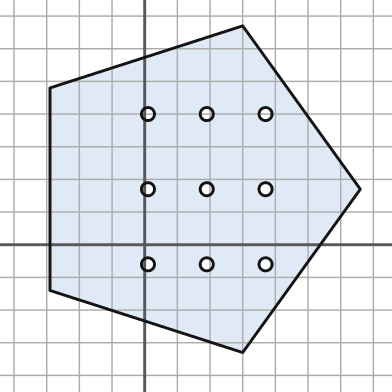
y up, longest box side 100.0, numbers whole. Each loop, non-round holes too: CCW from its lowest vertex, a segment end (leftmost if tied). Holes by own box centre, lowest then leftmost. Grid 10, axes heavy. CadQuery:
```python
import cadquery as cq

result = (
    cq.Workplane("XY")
    .moveTo(30.0, -33.0)
    .lineTo(66.0, 17.0)
    .lineTo(30.0, 67.0)
    .lineTo(-29.0, 48.0)
    .lineTo(-29.0, -14.0)
    .close()
    .moveTo(1.0, -6.0)
    .circle(2.0)
    .moveTo(19.0, -6.0)
    .circle(2.0)
    .moveTo(37.0, -6.0)
    .circle(2.0)
    .moveTo(1.0, 17.0)
    .circle(2.0)
    .moveTo(19.0, 17.0)
    .circle(2.0)
    .moveTo(37.0, 17.0)
    .circle(2.0)
    .moveTo(1.0, 40.0)
    .circle(2.0)
    .moveTo(19.0, 40.0)
    .circle(2.0)
    .moveTo(37.0, 40.0)
    .circle(2.0)
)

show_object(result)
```